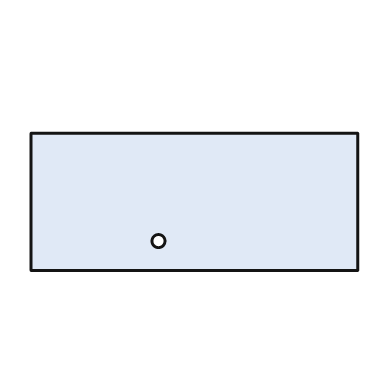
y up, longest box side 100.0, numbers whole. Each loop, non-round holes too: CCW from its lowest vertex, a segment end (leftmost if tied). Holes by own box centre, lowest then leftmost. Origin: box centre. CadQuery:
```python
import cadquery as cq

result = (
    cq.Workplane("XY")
    .moveTo(-50.0, -21.0)
    .lineTo(50.0, -21.0)
    .lineTo(50.0, 21.0)
    .lineTo(-50.0, 21.0)
    .close()
    .moveTo(-11.0, -12.0)
    .circle(2.0)
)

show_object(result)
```